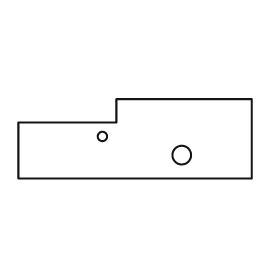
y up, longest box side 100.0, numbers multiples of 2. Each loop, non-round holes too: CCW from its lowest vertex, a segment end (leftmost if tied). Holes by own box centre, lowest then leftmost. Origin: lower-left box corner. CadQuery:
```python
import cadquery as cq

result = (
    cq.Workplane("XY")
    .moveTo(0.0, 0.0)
    .lineTo(100.0, 0.0)
    .lineTo(100.0, 34.0)
    .lineTo(42.0, 34.0)
    .lineTo(42.0, 24.0)
    .lineTo(0.0, 24.0)
    .close()
    .moveTo(70.0, 10.0)
    .circle(4.0)
    .moveTo(36.0, 18.0)
    .circle(2.0)
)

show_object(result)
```